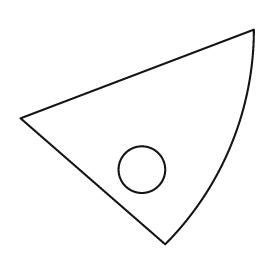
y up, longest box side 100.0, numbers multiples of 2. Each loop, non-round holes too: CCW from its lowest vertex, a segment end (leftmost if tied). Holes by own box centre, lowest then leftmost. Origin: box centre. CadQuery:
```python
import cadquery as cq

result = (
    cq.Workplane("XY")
    .moveTo(12.0, -46.0)
    .threePointArc((40.0, -4.0), (50.0, 46.0))
    .lineTo(-50.0, 8.0)
    .close()
    .moveTo(2.0, -14.0)
    .circle(10.0)
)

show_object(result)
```